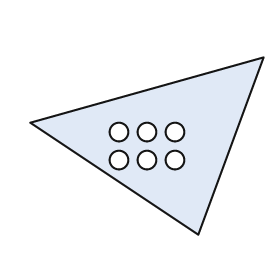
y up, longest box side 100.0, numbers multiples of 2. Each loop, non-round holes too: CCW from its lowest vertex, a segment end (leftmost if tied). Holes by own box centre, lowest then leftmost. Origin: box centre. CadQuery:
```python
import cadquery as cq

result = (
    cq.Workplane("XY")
    .moveTo(22.0, -38.0)
    .lineTo(50.0, 38.0)
    .lineTo(-50.0, 10.0)
    .close()
    .moveTo(-12.0, -6.0)
    .circle(4.0)
    .moveTo(0.0, -6.0)
    .circle(4.0)
    .moveTo(12.0, -6.0)
    .circle(4.0)
    .moveTo(-12.0, 6.0)
    .circle(4.0)
    .moveTo(0.0, 6.0)
    .circle(4.0)
    .moveTo(12.0, 6.0)
    .circle(4.0)
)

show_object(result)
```